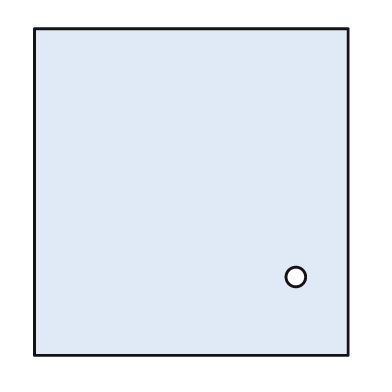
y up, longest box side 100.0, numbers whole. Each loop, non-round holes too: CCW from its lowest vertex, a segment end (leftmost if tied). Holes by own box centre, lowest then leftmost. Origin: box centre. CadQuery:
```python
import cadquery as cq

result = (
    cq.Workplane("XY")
    .moveTo(-48.0, -50.0)
    .lineTo(48.0, -50.0)
    .lineTo(48.0, 50.0)
    .lineTo(-48.0, 50.0)
    .close()
    .moveTo(32.0, -26.0)
    .circle(3.0)
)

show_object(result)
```